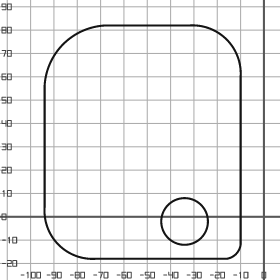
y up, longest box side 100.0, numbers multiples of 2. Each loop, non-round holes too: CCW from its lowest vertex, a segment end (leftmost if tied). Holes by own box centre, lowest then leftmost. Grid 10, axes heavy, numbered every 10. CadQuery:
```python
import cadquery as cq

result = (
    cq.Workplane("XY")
    .moveTo(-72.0, -18.0)
    .lineTo(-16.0, -18.0)
    .threePointArc((-12.0, -16.0), (-10.0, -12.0))
    .lineTo(-10.0, 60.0)
    .threePointArc((-16.0, 76.0), (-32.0, 82.0))
    .lineTo(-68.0, 82.0)
    .threePointArc((-86.0, 74.0), (-94.0, 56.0))
    .lineTo(-94.0, 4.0)
    .threePointArc((-88.0, -12.0), (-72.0, -18.0))
    .close()
    .moveTo(-34.0, -2.0)
    .circle(10.0)
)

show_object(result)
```